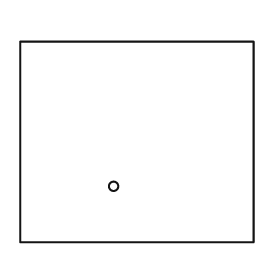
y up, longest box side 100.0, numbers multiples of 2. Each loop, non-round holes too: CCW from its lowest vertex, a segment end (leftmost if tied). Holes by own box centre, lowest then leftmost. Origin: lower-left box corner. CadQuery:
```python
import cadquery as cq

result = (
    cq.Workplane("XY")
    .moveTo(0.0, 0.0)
    .lineTo(100.0, 0.0)
    .lineTo(100.0, 86.0)
    .lineTo(0.0, 86.0)
    .close()
    .moveTo(40.0, 24.0)
    .circle(2.0)
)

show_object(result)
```